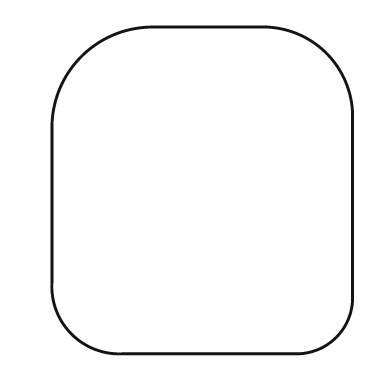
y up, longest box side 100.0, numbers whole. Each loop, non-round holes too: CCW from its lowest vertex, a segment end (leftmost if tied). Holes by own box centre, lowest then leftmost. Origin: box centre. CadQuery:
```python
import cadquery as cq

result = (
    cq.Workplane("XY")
    .moveTo(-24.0, -50.0)
    .lineTo(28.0, -50.0)
    .threePointArc((41.0, -45.0), (46.0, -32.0))
    .lineTo(46.0, 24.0)
    .threePointArc((38.0, 42.0), (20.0, 50.0))
    .lineTo(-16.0, 50.0)
    .threePointArc((-37.0, 41.0), (-46.0, 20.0))
    .lineTo(-46.0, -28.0)
    .threePointArc((-40.0, -44.0), (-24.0, -50.0))
    .close()
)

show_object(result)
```